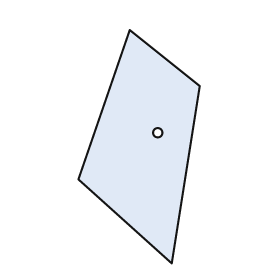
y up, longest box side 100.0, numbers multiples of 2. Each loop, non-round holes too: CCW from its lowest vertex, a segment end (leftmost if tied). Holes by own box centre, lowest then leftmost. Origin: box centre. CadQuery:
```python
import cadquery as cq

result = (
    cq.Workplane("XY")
    .moveTo(14.0, -50.0)
    .lineTo(26.0, 26.0)
    .lineTo(-4.0, 50.0)
    .lineTo(-26.0, -14.0)
    .close()
    .moveTo(8.0, 6.0)
    .circle(2.0)
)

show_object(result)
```